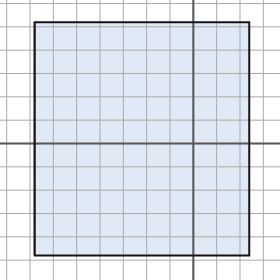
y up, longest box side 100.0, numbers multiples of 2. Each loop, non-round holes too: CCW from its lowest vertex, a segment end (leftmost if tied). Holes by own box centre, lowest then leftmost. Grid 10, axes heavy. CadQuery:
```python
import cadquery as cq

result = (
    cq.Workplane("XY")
    .moveTo(-68.0, -48.0)
    .lineTo(24.0, -48.0)
    .lineTo(24.0, 52.0)
    .lineTo(-68.0, 52.0)
    .close()
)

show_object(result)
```